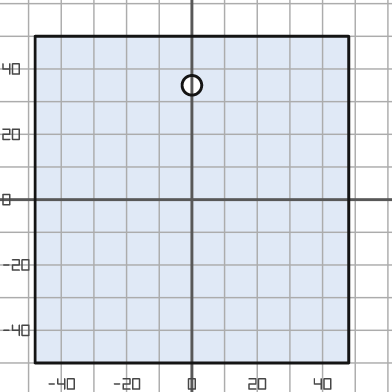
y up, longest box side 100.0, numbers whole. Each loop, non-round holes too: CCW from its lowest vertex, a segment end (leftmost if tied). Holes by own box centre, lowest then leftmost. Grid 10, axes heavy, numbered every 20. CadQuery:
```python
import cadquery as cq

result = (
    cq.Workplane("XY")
    .moveTo(-48.0, -50.0)
    .lineTo(48.0, -50.0)
    .lineTo(48.0, 50.0)
    .lineTo(-48.0, 50.0)
    .close()
    .moveTo(0.0, 35.0)
    .circle(3.0)
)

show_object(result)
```